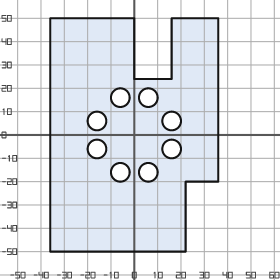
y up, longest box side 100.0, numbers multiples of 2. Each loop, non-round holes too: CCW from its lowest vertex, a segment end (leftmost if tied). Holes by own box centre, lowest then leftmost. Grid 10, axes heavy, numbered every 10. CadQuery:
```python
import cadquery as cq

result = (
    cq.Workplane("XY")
    .moveTo(-36.0, -50.0)
    .lineTo(22.0, -50.0)
    .lineTo(22.0, -20.0)
    .lineTo(36.0, -20.0)
    .lineTo(36.0, 50.0)
    .lineTo(16.0, 50.0)
    .lineTo(16.0, 24.0)
    .lineTo(0.0, 24.0)
    .lineTo(0.0, 50.0)
    .lineTo(-36.0, 50.0)
    .close()
    .moveTo(-6.0, -16.0)
    .circle(4.0)
    .moveTo(6.0, -16.0)
    .circle(4.0)
    .moveTo(-16.0, -6.0)
    .circle(4.0)
    .moveTo(16.0, -6.0)
    .circle(4.0)
    .moveTo(-16.0, 6.0)
    .circle(4.0)
    .moveTo(16.0, 6.0)
    .circle(4.0)
    .moveTo(-6.0, 16.0)
    .circle(4.0)
    .moveTo(6.0, 16.0)
    .circle(4.0)
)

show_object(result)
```